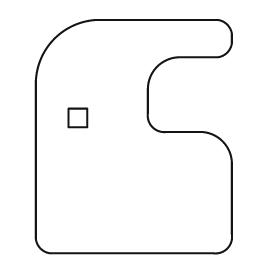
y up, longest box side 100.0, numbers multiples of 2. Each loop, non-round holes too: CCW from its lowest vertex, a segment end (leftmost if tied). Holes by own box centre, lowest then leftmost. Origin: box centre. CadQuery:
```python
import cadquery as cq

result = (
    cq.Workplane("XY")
    .moveTo(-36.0, -50.0)
    .lineTo(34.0, -50.0)
    .threePointArc((40.0, -48.0), (42.0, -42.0))
    .lineTo(42.0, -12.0)
    .threePointArc((38.0, -2.0), (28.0, 2.0))
    .lineTo(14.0, 2.0)
    .threePointArc((8.0, 4.0), (6.0, 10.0))
    .lineTo(6.0, 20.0)
    .threePointArc((10.0, 30.0), (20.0, 34.0))
    .lineTo(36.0, 34.0)
    .threePointArc((40.0, 36.0), (42.0, 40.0))
    .lineTo(42.0, 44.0)
    .threePointArc((40.0, 48.0), (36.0, 50.0))
    .lineTo(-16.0, 50.0)
    .threePointArc((-34.0, 42.0), (-42.0, 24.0))
    .lineTo(-42.0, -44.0)
    .threePointArc((-40.0, -48.0), (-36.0, -50.0))
    .close()
    .moveTo(-28.0, 4.0)
    .lineTo(-20.0, 4.0)
    .lineTo(-20.0, 12.0)
    .lineTo(-28.0, 12.0)
    .close()
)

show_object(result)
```